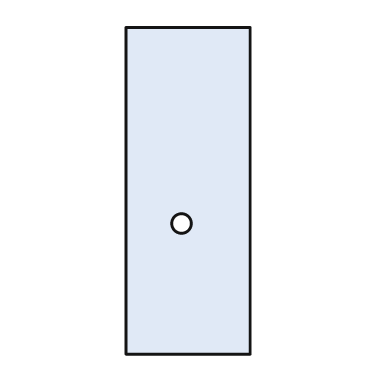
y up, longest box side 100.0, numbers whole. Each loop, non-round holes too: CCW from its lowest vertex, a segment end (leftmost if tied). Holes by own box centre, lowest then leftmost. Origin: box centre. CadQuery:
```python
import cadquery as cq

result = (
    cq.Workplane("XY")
    .moveTo(-19.0, -50.0)
    .lineTo(19.0, -50.0)
    .lineTo(19.0, 50.0)
    .lineTo(-19.0, 50.0)
    .close()
    .moveTo(-2.0, -10.0)
    .circle(3.0)
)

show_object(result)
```